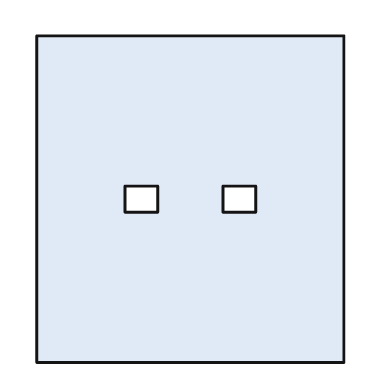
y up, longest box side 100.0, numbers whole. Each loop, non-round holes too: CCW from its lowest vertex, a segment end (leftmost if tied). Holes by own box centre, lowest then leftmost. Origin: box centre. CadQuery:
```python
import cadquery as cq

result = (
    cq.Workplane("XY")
    .moveTo(-47.0, -50.0)
    .lineTo(47.0, -50.0)
    .lineTo(47.0, 50.0)
    .lineTo(-47.0, 50.0)
    .close()
    .moveTo(-20.0, -4.0)
    .lineTo(-10.0, -4.0)
    .lineTo(-10.0, 4.0)
    .lineTo(-20.0, 4.0)
    .close()
    .moveTo(10.0, -4.0)
    .lineTo(20.0, -4.0)
    .lineTo(20.0, 4.0)
    .lineTo(10.0, 4.0)
    .close()
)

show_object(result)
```